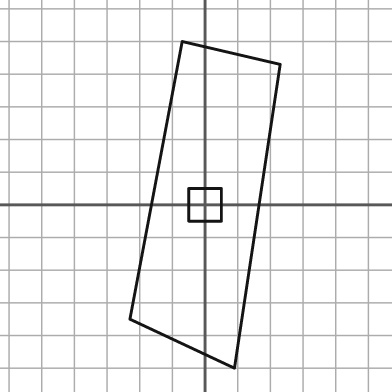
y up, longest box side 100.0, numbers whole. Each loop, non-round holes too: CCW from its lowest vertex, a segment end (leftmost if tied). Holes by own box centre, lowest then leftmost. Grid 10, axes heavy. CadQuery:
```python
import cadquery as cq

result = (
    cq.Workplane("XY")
    .moveTo(9.0, -50.0)
    .lineTo(23.0, 43.0)
    .lineTo(-7.0, 50.0)
    .lineTo(-23.0, -35.0)
    .close()
    .moveTo(-5.0, -5.0)
    .lineTo(5.0, -5.0)
    .lineTo(5.0, 5.0)
    .lineTo(-5.0, 5.0)
    .close()
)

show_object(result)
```